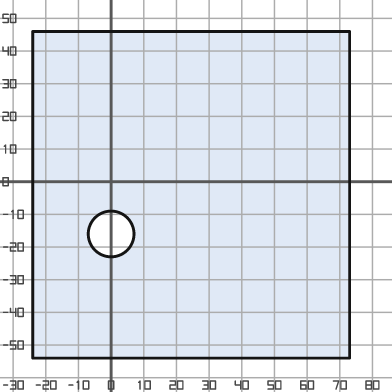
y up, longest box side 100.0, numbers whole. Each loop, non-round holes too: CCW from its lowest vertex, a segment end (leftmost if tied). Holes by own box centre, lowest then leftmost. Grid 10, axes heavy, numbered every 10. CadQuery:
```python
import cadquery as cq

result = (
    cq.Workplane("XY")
    .moveTo(-24.0, -54.0)
    .lineTo(73.0, -54.0)
    .lineTo(73.0, 46.0)
    .lineTo(-24.0, 46.0)
    .close()
    .moveTo(0.0, -16.0)
    .circle(7.0)
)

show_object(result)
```